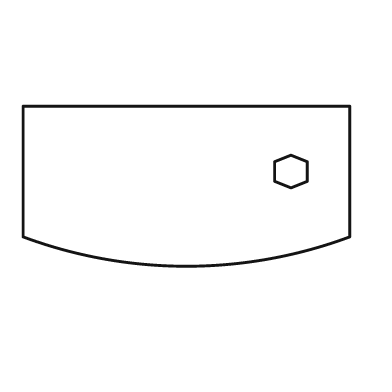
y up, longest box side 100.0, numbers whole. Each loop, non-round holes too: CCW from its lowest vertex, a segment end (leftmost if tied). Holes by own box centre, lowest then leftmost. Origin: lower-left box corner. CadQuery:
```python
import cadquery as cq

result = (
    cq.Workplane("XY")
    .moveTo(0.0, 9.0)
    .threePointArc((50.0, 0.0), (100.0, 9.0))
    .lineTo(100.0, 49.0)
    .lineTo(0.0, 49.0)
    .close()
    .moveTo(82.0, 24.0)
    .lineTo(87.0, 26.0)
    .lineTo(87.0, 32.0)
    .lineTo(82.0, 34.0)
    .lineTo(77.0, 32.0)
    .lineTo(77.0, 26.0)
    .close()
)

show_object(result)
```